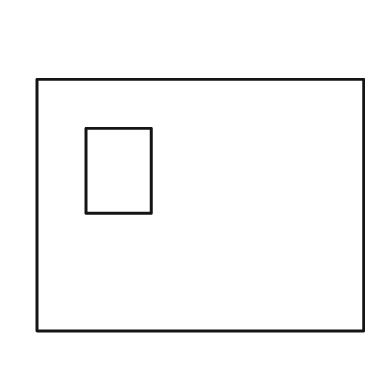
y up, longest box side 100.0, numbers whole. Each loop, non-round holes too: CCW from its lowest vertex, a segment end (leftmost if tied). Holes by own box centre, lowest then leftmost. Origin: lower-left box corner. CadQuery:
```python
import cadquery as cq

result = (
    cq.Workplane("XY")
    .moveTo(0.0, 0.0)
    .lineTo(100.0, 0.0)
    .lineTo(100.0, 77.0)
    .lineTo(0.0, 77.0)
    .close()
    .moveTo(15.0, 36.0)
    .lineTo(35.0, 36.0)
    .lineTo(35.0, 62.0)
    .lineTo(15.0, 62.0)
    .close()
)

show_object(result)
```